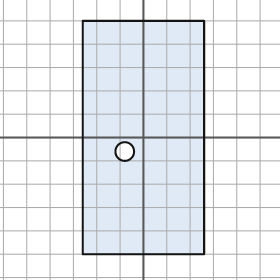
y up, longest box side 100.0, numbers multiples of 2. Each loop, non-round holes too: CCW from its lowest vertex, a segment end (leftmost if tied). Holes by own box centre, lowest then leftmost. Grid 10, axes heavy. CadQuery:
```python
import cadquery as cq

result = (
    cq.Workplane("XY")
    .moveTo(-26.0, -50.0)
    .lineTo(26.0, -50.0)
    .lineTo(26.0, 50.0)
    .lineTo(-26.0, 50.0)
    .close()
    .moveTo(-8.0, -6.0)
    .circle(4.0)
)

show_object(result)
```